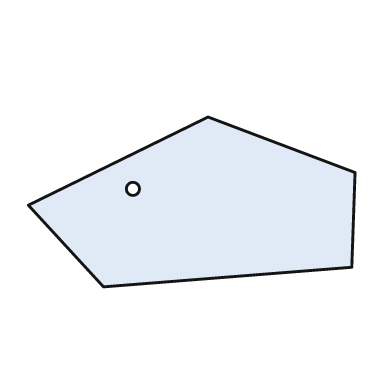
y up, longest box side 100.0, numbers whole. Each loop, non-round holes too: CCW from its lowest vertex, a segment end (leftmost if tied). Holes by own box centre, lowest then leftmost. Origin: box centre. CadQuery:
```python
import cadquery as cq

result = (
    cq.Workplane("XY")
    .moveTo(-27.0, -26.0)
    .lineTo(49.0, -20.0)
    .lineTo(50.0, 9.0)
    .lineTo(5.0, 26.0)
    .lineTo(-50.0, -1.0)
    .close()
    .moveTo(-18.0, 4.0)
    .circle(2.0)
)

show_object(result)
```